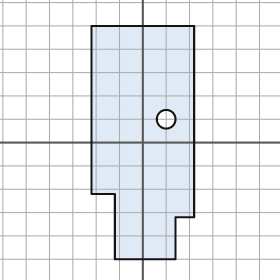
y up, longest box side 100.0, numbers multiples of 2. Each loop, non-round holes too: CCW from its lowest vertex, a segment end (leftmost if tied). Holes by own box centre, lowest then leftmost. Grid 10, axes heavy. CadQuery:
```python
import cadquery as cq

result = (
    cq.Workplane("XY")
    .moveTo(-12.0, -50.0)
    .lineTo(14.0, -50.0)
    .lineTo(14.0, -32.0)
    .lineTo(22.0, -32.0)
    .lineTo(22.0, 50.0)
    .lineTo(-22.0, 50.0)
    .lineTo(-22.0, -22.0)
    .lineTo(-12.0, -22.0)
    .close()
    .moveTo(10.0, 10.0)
    .circle(4.0)
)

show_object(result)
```